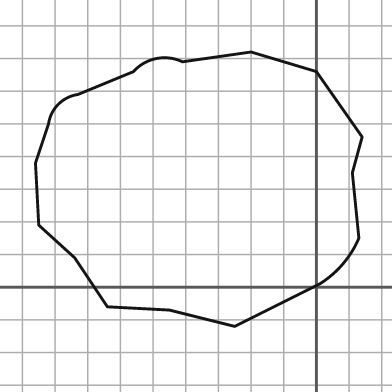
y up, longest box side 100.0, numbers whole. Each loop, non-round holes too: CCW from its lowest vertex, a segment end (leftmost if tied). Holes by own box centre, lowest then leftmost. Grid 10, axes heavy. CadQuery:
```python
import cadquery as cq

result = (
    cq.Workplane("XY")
    .moveTo(-25.0, -12.0)
    .lineTo(1.0, 1.0)
    .threePointArc((8.0, 7.0), (13.0, 15.0))
    .lineTo(11.0, 35.0)
    .lineTo(14.0, 46.0)
    .lineTo(0.0, 66.0)
    .lineTo(-20.0, 72.0)
    .lineTo(-41.0, 69.0)
    .threePointArc((-49.0, 70.0), (-56.0, 66.0))
    .lineTo(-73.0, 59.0)
    .threePointArc((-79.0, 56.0), (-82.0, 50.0))
    .lineTo(-86.0, 38.0)
    .lineTo(-85.0, 19.0)
    .lineTo(-74.0, 9.0)
    .lineTo(-64.0, -6.0)
    .lineTo(-45.0, -7.0)
    .close()
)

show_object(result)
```